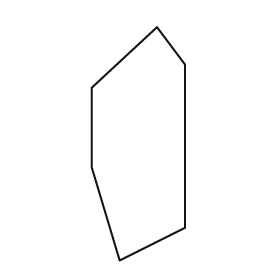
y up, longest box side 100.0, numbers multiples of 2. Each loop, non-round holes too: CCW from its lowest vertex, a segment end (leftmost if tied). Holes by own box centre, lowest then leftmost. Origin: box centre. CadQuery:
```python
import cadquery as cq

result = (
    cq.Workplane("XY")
    .moveTo(-8.0, -50.0)
    .lineTo(20.0, -36.0)
    .lineTo(20.0, 34.0)
    .lineTo(8.0, 50.0)
    .lineTo(-20.0, 24.0)
    .lineTo(-20.0, -10.0)
    .close()
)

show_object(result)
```